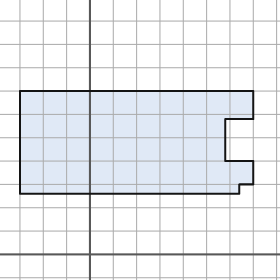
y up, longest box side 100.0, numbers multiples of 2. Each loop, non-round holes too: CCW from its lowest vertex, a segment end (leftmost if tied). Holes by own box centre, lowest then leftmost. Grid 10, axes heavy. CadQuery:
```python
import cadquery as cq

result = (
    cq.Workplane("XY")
    .moveTo(-30.0, 26.0)
    .lineTo(64.0, 26.0)
    .lineTo(64.0, 30.0)
    .lineTo(70.0, 30.0)
    .lineTo(70.0, 40.0)
    .lineTo(58.0, 40.0)
    .lineTo(58.0, 58.0)
    .lineTo(70.0, 58.0)
    .lineTo(70.0, 70.0)
    .lineTo(-30.0, 70.0)
    .close()
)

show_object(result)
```